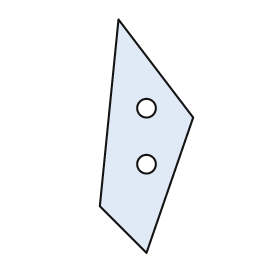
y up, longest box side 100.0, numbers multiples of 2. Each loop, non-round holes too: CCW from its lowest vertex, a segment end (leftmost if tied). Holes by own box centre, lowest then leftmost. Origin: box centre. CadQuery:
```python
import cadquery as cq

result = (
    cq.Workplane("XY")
    .moveTo(0.0, -50.0)
    .lineTo(20.0, 8.0)
    .lineTo(-12.0, 50.0)
    .lineTo(-20.0, -30.0)
    .close()
    .moveTo(0.0, -12.0)
    .circle(4.0)
    .moveTo(0.0, 12.0)
    .circle(4.0)
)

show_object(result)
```